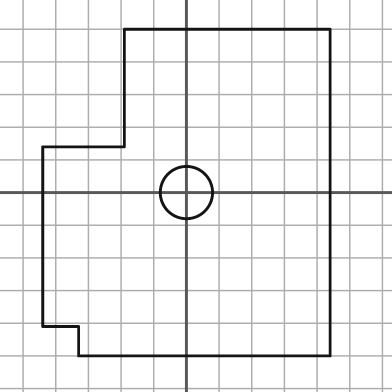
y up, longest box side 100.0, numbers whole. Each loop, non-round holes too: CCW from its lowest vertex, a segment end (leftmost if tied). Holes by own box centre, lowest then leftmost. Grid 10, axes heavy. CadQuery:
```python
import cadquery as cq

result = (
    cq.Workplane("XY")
    .moveTo(-33.0, -50.0)
    .lineTo(44.0, -50.0)
    .lineTo(44.0, 50.0)
    .lineTo(-19.0, 50.0)
    .lineTo(-19.0, 14.0)
    .lineTo(-44.0, 14.0)
    .lineTo(-44.0, -41.0)
    .lineTo(-33.0, -41.0)
    .close()
    .moveTo(0.0, 0.0)
    .circle(8.0)
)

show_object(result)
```